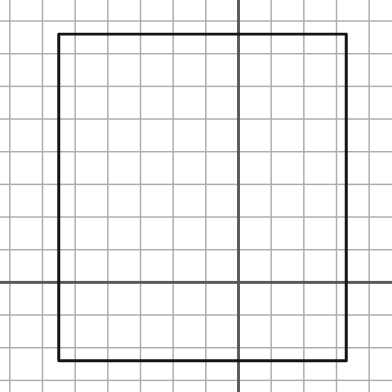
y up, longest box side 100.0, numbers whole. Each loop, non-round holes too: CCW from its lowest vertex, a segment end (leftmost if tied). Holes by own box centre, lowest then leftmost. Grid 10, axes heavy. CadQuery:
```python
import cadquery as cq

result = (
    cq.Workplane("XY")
    .moveTo(-55.0, -24.0)
    .lineTo(33.0, -24.0)
    .lineTo(33.0, 76.0)
    .lineTo(-55.0, 76.0)
    .close()
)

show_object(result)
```